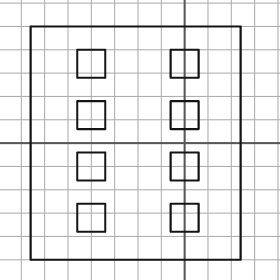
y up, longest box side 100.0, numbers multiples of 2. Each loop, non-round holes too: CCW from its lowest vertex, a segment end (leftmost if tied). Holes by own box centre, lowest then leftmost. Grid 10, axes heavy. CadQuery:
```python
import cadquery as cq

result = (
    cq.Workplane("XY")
    .moveTo(-66.0, -50.0)
    .lineTo(24.0, -50.0)
    .lineTo(24.0, 50.0)
    .lineTo(-66.0, 50.0)
    .close()
    .moveTo(-46.0, -38.0)
    .lineTo(-34.0, -38.0)
    .lineTo(-34.0, -26.0)
    .lineTo(-46.0, -26.0)
    .close()
    .moveTo(-6.0, -38.0)
    .lineTo(6.0, -38.0)
    .lineTo(6.0, -26.0)
    .lineTo(-6.0, -26.0)
    .close()
    .moveTo(-46.0, -16.0)
    .lineTo(-34.0, -16.0)
    .lineTo(-34.0, -4.0)
    .lineTo(-46.0, -4.0)
    .close()
    .moveTo(-6.0, -16.0)
    .lineTo(6.0, -16.0)
    .lineTo(6.0, -4.0)
    .lineTo(-6.0, -4.0)
    .close()
    .moveTo(-46.0, 6.0)
    .lineTo(-34.0, 6.0)
    .lineTo(-34.0, 18.0)
    .lineTo(-46.0, 18.0)
    .close()
    .moveTo(-6.0, 6.0)
    .lineTo(6.0, 6.0)
    .lineTo(6.0, 18.0)
    .lineTo(-6.0, 18.0)
    .close()
    .moveTo(-46.0, 28.0)
    .lineTo(-34.0, 28.0)
    .lineTo(-34.0, 40.0)
    .lineTo(-46.0, 40.0)
    .close()
    .moveTo(-6.0, 28.0)
    .lineTo(6.0, 28.0)
    .lineTo(6.0, 40.0)
    .lineTo(-6.0, 40.0)
    .close()
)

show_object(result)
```